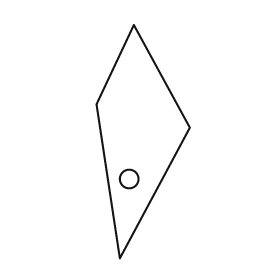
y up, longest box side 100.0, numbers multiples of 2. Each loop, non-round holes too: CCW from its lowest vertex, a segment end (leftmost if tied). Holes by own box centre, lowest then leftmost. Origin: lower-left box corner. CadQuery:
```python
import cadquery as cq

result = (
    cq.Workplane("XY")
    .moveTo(10.0, 0.0)
    .lineTo(40.0, 56.0)
    .lineTo(16.0, 100.0)
    .lineTo(0.0, 66.0)
    .close()
    .moveTo(14.0, 34.0)
    .circle(4.0)
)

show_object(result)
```